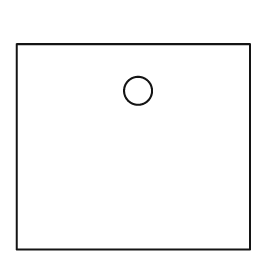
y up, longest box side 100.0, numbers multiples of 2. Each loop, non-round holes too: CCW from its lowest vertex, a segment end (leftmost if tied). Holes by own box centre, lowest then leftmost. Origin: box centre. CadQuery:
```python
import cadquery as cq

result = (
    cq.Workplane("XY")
    .moveTo(-50.0, -44.0)
    .lineTo(50.0, -44.0)
    .lineTo(50.0, 44.0)
    .lineTo(-50.0, 44.0)
    .close()
    .moveTo(2.0, 24.0)
    .circle(6.0)
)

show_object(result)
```